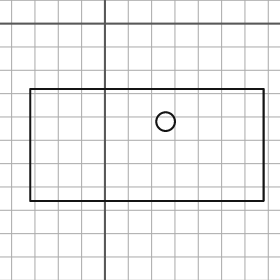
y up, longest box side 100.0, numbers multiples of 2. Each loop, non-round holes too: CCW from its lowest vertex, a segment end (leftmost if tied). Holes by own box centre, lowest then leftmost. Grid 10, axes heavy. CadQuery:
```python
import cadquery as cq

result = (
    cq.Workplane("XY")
    .moveTo(-32.0, -76.0)
    .lineTo(68.0, -76.0)
    .lineTo(68.0, -28.0)
    .lineTo(-32.0, -28.0)
    .close()
    .moveTo(26.0, -42.0)
    .circle(4.0)
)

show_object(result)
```